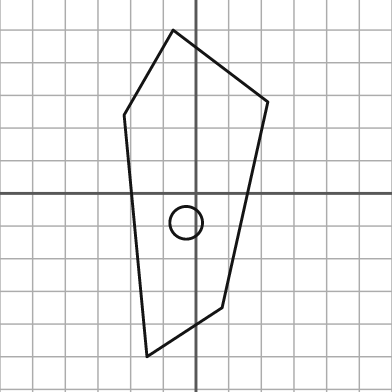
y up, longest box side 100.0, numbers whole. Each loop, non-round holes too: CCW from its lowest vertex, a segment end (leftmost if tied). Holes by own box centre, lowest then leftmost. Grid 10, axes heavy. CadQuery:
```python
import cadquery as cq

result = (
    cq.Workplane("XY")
    .moveTo(-15.0, -50.0)
    .lineTo(8.0, -35.0)
    .lineTo(22.0, 28.0)
    .lineTo(-7.0, 50.0)
    .lineTo(-22.0, 24.0)
    .close()
    .moveTo(-3.0, -9.0)
    .circle(5.0)
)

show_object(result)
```